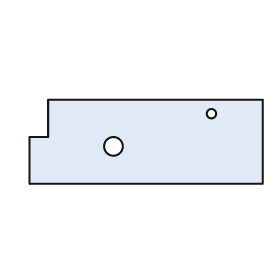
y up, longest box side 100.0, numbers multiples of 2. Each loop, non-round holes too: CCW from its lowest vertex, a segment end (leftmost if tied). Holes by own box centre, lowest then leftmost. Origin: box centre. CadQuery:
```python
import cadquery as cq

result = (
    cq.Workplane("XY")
    .moveTo(-50.0, -18.0)
    .lineTo(50.0, -18.0)
    .lineTo(50.0, 18.0)
    .lineTo(-42.0, 18.0)
    .lineTo(-42.0, 2.0)
    .lineTo(-50.0, 2.0)
    .close()
    .moveTo(-14.0, -2.0)
    .circle(4.0)
    .moveTo(28.0, 12.0)
    .circle(2.0)
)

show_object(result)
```